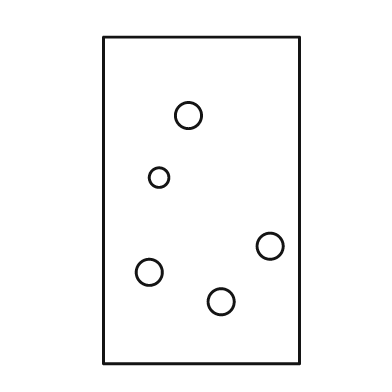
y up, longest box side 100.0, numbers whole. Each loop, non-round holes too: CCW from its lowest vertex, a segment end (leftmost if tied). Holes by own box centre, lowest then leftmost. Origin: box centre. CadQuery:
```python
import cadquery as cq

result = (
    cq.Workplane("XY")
    .moveTo(-30.0, -50.0)
    .lineTo(30.0, -50.0)
    .lineTo(30.0, 50.0)
    .lineTo(-30.0, 50.0)
    .close()
    .moveTo(6.0, -31.0)
    .circle(4.0)
    .moveTo(-16.0, -22.0)
    .circle(4.0)
    .moveTo(21.0, -14.0)
    .circle(4.0)
    .moveTo(-13.0, 7.0)
    .circle(3.0)
    .moveTo(-4.0, 26.0)
    .circle(4.0)
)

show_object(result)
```